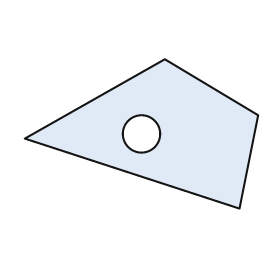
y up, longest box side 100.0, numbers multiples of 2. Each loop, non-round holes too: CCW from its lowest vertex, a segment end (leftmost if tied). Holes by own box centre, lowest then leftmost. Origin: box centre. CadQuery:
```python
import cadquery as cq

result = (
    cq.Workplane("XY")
    .moveTo(42.0, -32.0)
    .lineTo(50.0, 8.0)
    .lineTo(10.0, 32.0)
    .lineTo(-50.0, -2.0)
    .close()
    .moveTo(0.0, 0.0)
    .circle(8.0)
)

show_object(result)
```